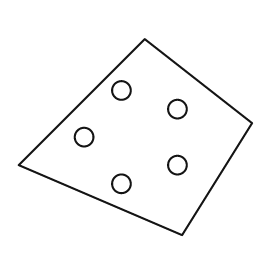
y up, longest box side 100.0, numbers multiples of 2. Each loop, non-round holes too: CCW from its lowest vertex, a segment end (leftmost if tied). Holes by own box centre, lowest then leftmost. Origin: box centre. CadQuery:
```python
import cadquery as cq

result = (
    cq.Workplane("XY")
    .moveTo(20.0, -42.0)
    .lineTo(50.0, 6.0)
    .lineTo(4.0, 42.0)
    .lineTo(-50.0, -12.0)
    .close()
    .moveTo(-6.0, -20.0)
    .circle(4.0)
    .moveTo(18.0, -12.0)
    .circle(4.0)
    .moveTo(-22.0, 0.0)
    .circle(4.0)
    .moveTo(18.0, 12.0)
    .circle(4.0)
    .moveTo(-6.0, 20.0)
    .circle(4.0)
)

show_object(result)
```